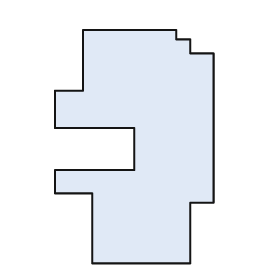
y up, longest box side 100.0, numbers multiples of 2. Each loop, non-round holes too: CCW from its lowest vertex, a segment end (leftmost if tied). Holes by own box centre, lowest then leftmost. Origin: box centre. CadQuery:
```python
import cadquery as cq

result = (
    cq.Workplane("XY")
    .moveTo(-18.0, -50.0)
    .lineTo(24.0, -50.0)
    .lineTo(24.0, -24.0)
    .lineTo(34.0, -24.0)
    .lineTo(34.0, 40.0)
    .lineTo(24.0, 40.0)
    .lineTo(24.0, 46.0)
    .lineTo(18.0, 46.0)
    .lineTo(18.0, 50.0)
    .lineTo(-22.0, 50.0)
    .lineTo(-22.0, 24.0)
    .lineTo(-34.0, 24.0)
    .lineTo(-34.0, 8.0)
    .lineTo(0.0, 8.0)
    .lineTo(0.0, -10.0)
    .lineTo(-34.0, -10.0)
    .lineTo(-34.0, -20.0)
    .lineTo(-18.0, -20.0)
    .close()
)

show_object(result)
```